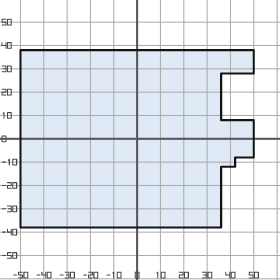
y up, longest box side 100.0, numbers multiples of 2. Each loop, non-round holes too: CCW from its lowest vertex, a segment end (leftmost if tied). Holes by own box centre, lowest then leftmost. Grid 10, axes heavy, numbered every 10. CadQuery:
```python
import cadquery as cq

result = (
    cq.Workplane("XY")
    .moveTo(-50.0, -38.0)
    .lineTo(36.0, -38.0)
    .lineTo(36.0, -12.0)
    .lineTo(42.0, -12.0)
    .lineTo(42.0, -8.0)
    .lineTo(50.0, -8.0)
    .lineTo(50.0, 8.0)
    .lineTo(36.0, 8.0)
    .lineTo(36.0, 28.0)
    .lineTo(50.0, 28.0)
    .lineTo(50.0, 38.0)
    .lineTo(-50.0, 38.0)
    .close()
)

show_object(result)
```